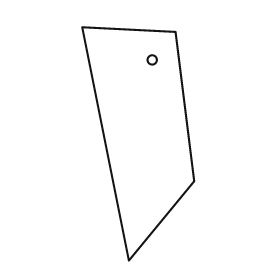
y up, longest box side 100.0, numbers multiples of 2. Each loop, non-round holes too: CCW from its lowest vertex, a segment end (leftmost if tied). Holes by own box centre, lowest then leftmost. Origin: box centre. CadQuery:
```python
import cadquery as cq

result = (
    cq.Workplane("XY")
    .moveTo(-4.0, -50.0)
    .lineTo(24.0, -16.0)
    .lineTo(16.0, 48.0)
    .lineTo(-24.0, 50.0)
    .close()
    .moveTo(6.0, 36.0)
    .circle(2.0)
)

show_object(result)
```